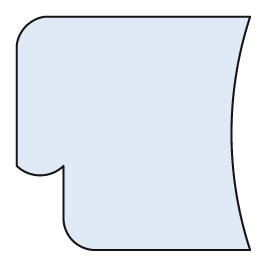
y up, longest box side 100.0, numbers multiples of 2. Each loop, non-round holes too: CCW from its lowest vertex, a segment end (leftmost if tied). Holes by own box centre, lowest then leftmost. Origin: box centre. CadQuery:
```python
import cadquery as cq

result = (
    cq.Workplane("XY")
    .moveTo(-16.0, -50.0)
    .lineTo(50.0, -50.0)
    .threePointArc((42.0, 0.0), (50.0, 50.0))
    .lineTo(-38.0, 50.0)
    .threePointArc((-46.0, 46.0), (-50.0, 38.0))
    .lineTo(-50.0, -14.0)
    .threePointArc((-40.0, -18.0), (-30.0, -14.0))
    .lineTo(-30.0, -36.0)
    .threePointArc((-26.0, -46.0), (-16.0, -50.0))
    .close()
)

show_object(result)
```